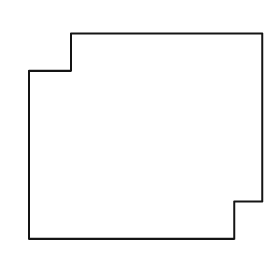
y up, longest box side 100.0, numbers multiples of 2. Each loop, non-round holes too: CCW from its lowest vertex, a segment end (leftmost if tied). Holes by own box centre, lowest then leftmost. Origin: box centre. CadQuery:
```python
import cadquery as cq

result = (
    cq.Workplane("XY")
    .moveTo(-50.0, -44.0)
    .lineTo(38.0, -44.0)
    .lineTo(38.0, -28.0)
    .lineTo(50.0, -28.0)
    .lineTo(50.0, 44.0)
    .lineTo(-32.0, 44.0)
    .lineTo(-32.0, 28.0)
    .lineTo(-50.0, 28.0)
    .close()
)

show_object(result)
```